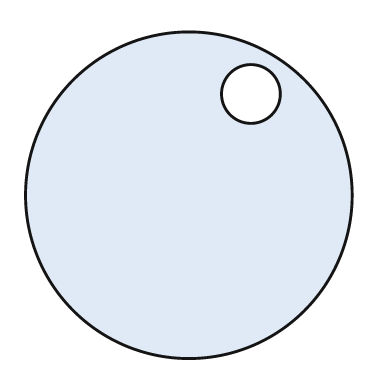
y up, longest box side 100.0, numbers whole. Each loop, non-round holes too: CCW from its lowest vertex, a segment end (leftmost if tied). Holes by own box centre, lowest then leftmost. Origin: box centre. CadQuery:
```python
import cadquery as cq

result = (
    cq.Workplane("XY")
    .moveTo(0.0, 0.0)
    .circle(50.0)
    .moveTo(19.0, 31.0)
    .circle(9.0)
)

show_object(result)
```